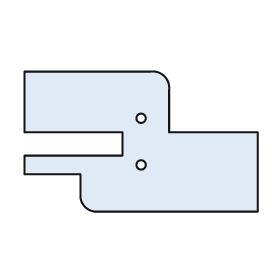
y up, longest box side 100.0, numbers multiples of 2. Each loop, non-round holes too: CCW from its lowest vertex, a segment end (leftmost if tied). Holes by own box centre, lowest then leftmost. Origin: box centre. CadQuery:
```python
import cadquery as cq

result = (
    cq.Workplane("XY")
    .moveTo(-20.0, -30.0)
    .lineTo(50.0, -30.0)
    .lineTo(50.0, 4.0)
    .lineTo(12.0, 4.0)
    .lineTo(12.0, 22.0)
    .threePointArc((10.0, 28.0), (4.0, 30.0))
    .lineTo(-50.0, 30.0)
    .lineTo(-50.0, 4.0)
    .lineTo(-8.0, 4.0)
    .lineTo(-8.0, -6.0)
    .lineTo(-50.0, -6.0)
    .lineTo(-50.0, -14.0)
    .lineTo(-26.0, -14.0)
    .lineTo(-26.0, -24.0)
    .threePointArc((-24.0, -28.0), (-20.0, -30.0))
    .close()
    .moveTo(0.0, -10.0)
    .circle(2.0)
    .moveTo(0.0, 10.0)
    .circle(2.0)
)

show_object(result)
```